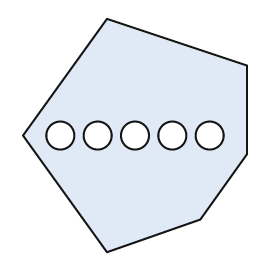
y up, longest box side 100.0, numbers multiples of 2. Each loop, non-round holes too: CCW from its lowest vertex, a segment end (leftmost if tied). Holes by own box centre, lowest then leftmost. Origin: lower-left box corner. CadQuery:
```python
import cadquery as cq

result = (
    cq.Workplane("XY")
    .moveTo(36.0, 0.0)
    .lineTo(76.0, 14.0)
    .lineTo(96.0, 42.0)
    .lineTo(96.0, 80.0)
    .lineTo(36.0, 100.0)
    .lineTo(0.0, 50.0)
    .close()
    .moveTo(16.0, 50.0)
    .circle(6.0)
    .moveTo(32.0, 50.0)
    .circle(6.0)
    .moveTo(48.0, 50.0)
    .circle(6.0)
    .moveTo(64.0, 50.0)
    .circle(6.0)
    .moveTo(80.0, 50.0)
    .circle(6.0)
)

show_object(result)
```